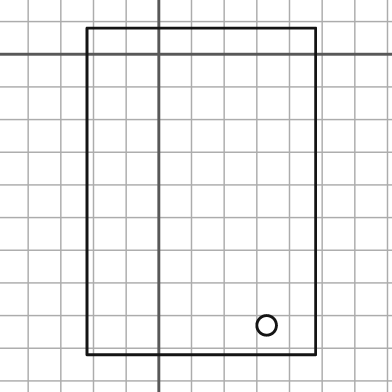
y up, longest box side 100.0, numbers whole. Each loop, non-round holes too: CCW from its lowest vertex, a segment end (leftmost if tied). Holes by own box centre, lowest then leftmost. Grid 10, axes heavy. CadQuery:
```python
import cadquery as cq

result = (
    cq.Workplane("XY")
    .moveTo(-22.0, -92.0)
    .lineTo(48.0, -92.0)
    .lineTo(48.0, 8.0)
    .lineTo(-22.0, 8.0)
    .close()
    .moveTo(33.0, -83.0)
    .circle(3.0)
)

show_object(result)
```